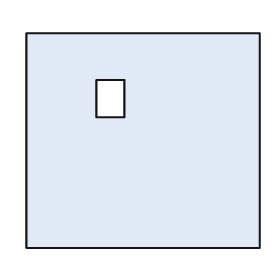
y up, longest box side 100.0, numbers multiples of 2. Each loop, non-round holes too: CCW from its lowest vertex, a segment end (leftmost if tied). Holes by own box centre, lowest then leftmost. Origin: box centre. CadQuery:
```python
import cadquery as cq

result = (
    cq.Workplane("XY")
    .moveTo(-50.0, -46.0)
    .lineTo(50.0, -46.0)
    .lineTo(50.0, 46.0)
    .lineTo(-50.0, 46.0)
    .close()
    .moveTo(-20.0, 10.0)
    .lineTo(-8.0, 10.0)
    .lineTo(-8.0, 26.0)
    .lineTo(-20.0, 26.0)
    .close()
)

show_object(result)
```